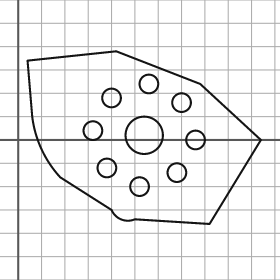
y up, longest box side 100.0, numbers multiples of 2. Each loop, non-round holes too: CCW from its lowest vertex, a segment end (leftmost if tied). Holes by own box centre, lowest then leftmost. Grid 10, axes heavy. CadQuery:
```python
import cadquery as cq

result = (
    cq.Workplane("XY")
    .moveTo(82.0, -36.0)
    .lineTo(104.0, 0.0)
    .lineTo(78.0, 24.0)
    .lineTo(42.0, 38.0)
    .lineTo(4.0, 34.0)
    .lineTo(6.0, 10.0)
    .threePointArc((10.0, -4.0), (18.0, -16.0))
    .lineTo(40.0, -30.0)
    .threePointArc((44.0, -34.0), (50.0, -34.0))
    .close()
    .moveTo(52.0, -20.0)
    .circle(4.0)
    .moveTo(68.0, -14.0)
    .circle(4.0)
    .moveTo(38.0, -12.0)
    .circle(4.0)
    .moveTo(76.0, 0.0)
    .circle(4.0)
    .moveTo(54.0, 2.0)
    .circle(8.0)
    .moveTo(32.0, 4.0)
    .circle(4.0)
    .moveTo(70.0, 16.0)
    .circle(4.0)
    .moveTo(40.0, 18.0)
    .circle(4.0)
    .moveTo(56.0, 24.0)
    .circle(4.0)
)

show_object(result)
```